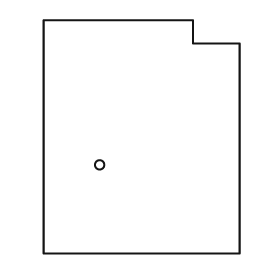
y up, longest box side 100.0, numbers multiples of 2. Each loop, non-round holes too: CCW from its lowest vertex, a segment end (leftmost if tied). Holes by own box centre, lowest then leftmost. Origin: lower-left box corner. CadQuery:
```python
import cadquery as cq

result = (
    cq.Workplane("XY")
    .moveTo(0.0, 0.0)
    .lineTo(84.0, 0.0)
    .lineTo(84.0, 90.0)
    .lineTo(64.0, 90.0)
    .lineTo(64.0, 100.0)
    .lineTo(0.0, 100.0)
    .close()
    .moveTo(24.0, 38.0)
    .circle(2.0)
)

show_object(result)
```